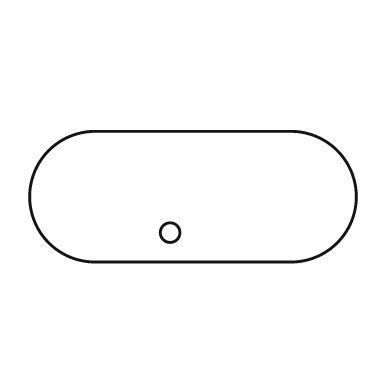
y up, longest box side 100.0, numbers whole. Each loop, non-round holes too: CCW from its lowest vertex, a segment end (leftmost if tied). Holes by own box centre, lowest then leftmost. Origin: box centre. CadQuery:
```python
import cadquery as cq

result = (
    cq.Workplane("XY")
    .moveTo(-30.0, -20.0)
    .lineTo(30.0, -20.0)
    .threePointArc((50.0, 0.0), (30.0, 20.0))
    .lineTo(-30.0, 20.0)
    .threePointArc((-50.0, 0.0), (-30.0, -20.0))
    .close()
    .moveTo(-7.0, -11.0)
    .circle(3.0)
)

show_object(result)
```